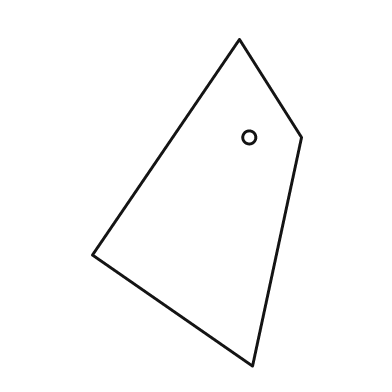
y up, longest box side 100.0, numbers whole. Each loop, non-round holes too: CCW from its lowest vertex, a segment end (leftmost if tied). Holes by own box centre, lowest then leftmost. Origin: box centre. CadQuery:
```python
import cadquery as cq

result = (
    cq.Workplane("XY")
    .moveTo(17.0, -50.0)
    .lineTo(32.0, 20.0)
    .lineTo(13.0, 50.0)
    .lineTo(-32.0, -16.0)
    .close()
    .moveTo(16.0, 20.0)
    .circle(2.0)
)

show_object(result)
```